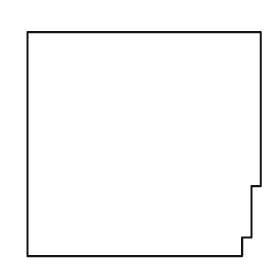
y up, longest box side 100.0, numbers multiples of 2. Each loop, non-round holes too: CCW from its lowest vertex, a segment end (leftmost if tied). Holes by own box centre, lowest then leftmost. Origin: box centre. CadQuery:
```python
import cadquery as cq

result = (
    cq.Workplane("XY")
    .moveTo(-50.0, -48.0)
    .lineTo(42.0, -48.0)
    .lineTo(42.0, -40.0)
    .lineTo(46.0, -40.0)
    .lineTo(46.0, -18.0)
    .lineTo(50.0, -18.0)
    .lineTo(50.0, 48.0)
    .lineTo(-50.0, 48.0)
    .close()
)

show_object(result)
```